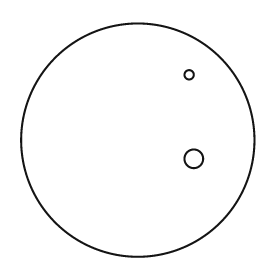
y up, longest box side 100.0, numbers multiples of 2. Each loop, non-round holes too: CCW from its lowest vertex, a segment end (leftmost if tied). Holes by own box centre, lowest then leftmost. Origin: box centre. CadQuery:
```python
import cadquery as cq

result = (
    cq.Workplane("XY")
    .moveTo(0.0, 0.0)
    .circle(50.0)
    .moveTo(24.0, -8.0)
    .circle(4.0)
    .moveTo(22.0, 28.0)
    .circle(2.0)
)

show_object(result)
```